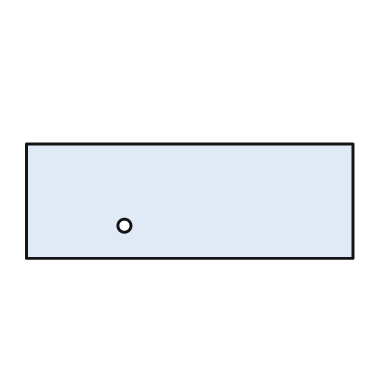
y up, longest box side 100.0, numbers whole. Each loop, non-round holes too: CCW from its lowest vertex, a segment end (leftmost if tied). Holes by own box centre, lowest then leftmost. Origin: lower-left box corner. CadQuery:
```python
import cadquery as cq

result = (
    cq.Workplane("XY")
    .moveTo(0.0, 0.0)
    .lineTo(100.0, 0.0)
    .lineTo(100.0, 35.0)
    .lineTo(0.0, 35.0)
    .close()
    .moveTo(30.0, 10.0)
    .circle(2.0)
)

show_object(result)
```